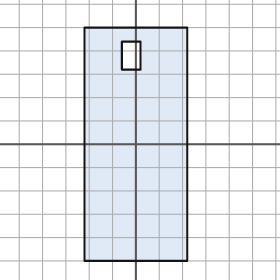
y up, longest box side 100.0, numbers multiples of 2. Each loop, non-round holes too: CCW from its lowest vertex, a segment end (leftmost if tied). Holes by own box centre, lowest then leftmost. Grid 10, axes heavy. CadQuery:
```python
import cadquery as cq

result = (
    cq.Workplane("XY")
    .moveTo(-22.0, -50.0)
    .lineTo(22.0, -50.0)
    .lineTo(22.0, 50.0)
    .lineTo(-22.0, 50.0)
    .close()
    .moveTo(-6.0, 32.0)
    .lineTo(2.0, 32.0)
    .lineTo(2.0, 44.0)
    .lineTo(-6.0, 44.0)
    .close()
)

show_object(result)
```